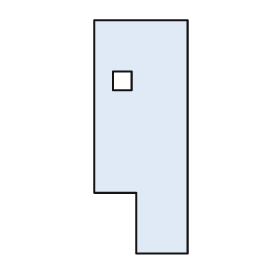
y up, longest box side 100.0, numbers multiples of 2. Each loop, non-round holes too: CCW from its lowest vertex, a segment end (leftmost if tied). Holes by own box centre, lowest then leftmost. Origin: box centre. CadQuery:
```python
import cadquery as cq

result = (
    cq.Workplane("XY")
    .moveTo(-2.0, -50.0)
    .lineTo(20.0, -50.0)
    .lineTo(20.0, 50.0)
    .lineTo(-20.0, 50.0)
    .lineTo(-20.0, -24.0)
    .lineTo(-2.0, -24.0)
    .close()
    .moveTo(-12.0, 20.0)
    .lineTo(-4.0, 20.0)
    .lineTo(-4.0, 28.0)
    .lineTo(-12.0, 28.0)
    .close()
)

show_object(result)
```